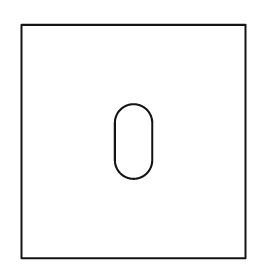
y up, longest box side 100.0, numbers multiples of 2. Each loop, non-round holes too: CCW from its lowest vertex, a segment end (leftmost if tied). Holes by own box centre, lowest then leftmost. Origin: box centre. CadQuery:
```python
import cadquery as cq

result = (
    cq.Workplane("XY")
    .moveTo(-48.0, -50.0)
    .lineTo(48.0, -50.0)
    .lineTo(48.0, 50.0)
    .lineTo(-48.0, 50.0)
    .close()
    .moveTo(-8.0, -8.0)
    .threePointArc((0.0, -16.0), (8.0, -8.0))
    .lineTo(8.0, 8.0)
    .threePointArc((0.0, 16.0), (-8.0, 8.0))
    .close()
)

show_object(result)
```